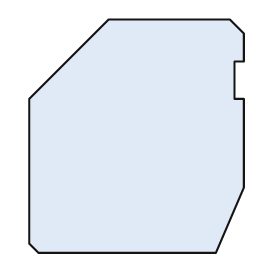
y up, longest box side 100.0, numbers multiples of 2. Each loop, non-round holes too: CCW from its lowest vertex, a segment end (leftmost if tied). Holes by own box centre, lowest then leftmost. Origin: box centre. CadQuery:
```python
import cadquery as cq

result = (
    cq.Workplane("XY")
    .moveTo(-42.0, -50.0)
    .lineTo(34.0, -50.0)
    .lineTo(46.0, -22.0)
    .lineTo(46.0, 16.0)
    .lineTo(42.0, 16.0)
    .lineTo(42.0, 32.0)
    .lineTo(46.0, 32.0)
    .lineTo(46.0, 44.0)
    .lineTo(40.0, 50.0)
    .lineTo(-12.0, 50.0)
    .lineTo(-46.0, 16.0)
    .lineTo(-46.0, -46.0)
    .close()
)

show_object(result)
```